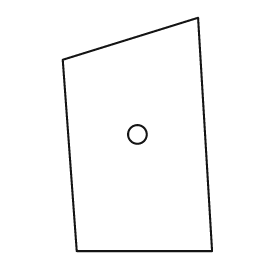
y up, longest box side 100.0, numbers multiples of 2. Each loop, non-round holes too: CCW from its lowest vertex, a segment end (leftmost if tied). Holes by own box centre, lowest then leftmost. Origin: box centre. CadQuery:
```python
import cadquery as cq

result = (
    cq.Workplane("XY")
    .moveTo(-26.0, -50.0)
    .lineTo(32.0, -50.0)
    .lineTo(26.0, 50.0)
    .lineTo(-32.0, 32.0)
    .close()
    .moveTo(0.0, 0.0)
    .circle(4.0)
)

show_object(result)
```